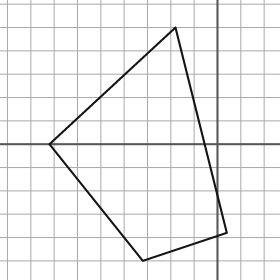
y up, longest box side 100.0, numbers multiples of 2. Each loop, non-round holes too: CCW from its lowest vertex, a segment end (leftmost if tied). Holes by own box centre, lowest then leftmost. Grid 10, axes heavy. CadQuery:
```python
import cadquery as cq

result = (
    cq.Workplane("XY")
    .moveTo(-32.0, -50.0)
    .lineTo(4.0, -38.0)
    .lineTo(-18.0, 50.0)
    .lineTo(-72.0, 0.0)
    .close()
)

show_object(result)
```